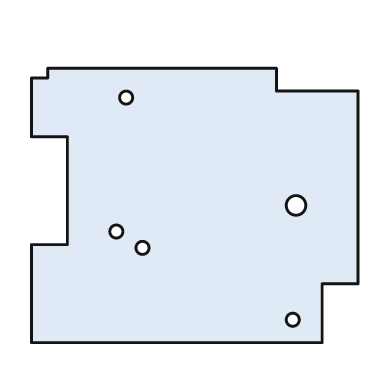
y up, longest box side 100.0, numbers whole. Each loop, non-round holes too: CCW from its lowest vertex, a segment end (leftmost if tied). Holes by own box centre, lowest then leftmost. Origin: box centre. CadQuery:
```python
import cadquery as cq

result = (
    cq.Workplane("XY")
    .moveTo(-50.0, -42.0)
    .lineTo(39.0, -42.0)
    .lineTo(39.0, -24.0)
    .lineTo(50.0, -24.0)
    .lineTo(50.0, 35.0)
    .lineTo(25.0, 35.0)
    .lineTo(25.0, 42.0)
    .lineTo(-45.0, 42.0)
    .lineTo(-45.0, 39.0)
    .lineTo(-50.0, 39.0)
    .lineTo(-50.0, 21.0)
    .lineTo(-39.0, 21.0)
    .lineTo(-39.0, -12.0)
    .lineTo(-50.0, -12.0)
    .close()
    .moveTo(30.0, -35.0)
    .circle(2.0)
    .moveTo(-16.0, -13.0)
    .circle(2.0)
    .moveTo(-24.0, -8.0)
    .circle(2.0)
    .moveTo(31.0, 0.0)
    .circle(3.0)
    .moveTo(-21.0, 33.0)
    .circle(2.0)
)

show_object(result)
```